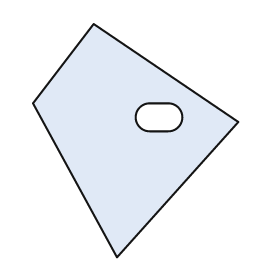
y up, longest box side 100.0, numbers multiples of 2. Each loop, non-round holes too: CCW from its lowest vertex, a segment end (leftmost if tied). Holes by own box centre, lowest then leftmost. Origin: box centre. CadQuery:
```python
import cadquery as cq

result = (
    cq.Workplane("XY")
    .moveTo(-8.0, -50.0)
    .lineTo(44.0, 8.0)
    .lineTo(-18.0, 50.0)
    .lineTo(-44.0, 16.0)
    .close()
    .moveTo(6.0, 4.0)
    .lineTo(14.0, 4.0)
    .threePointArc((20.0, 10.0), (14.0, 16.0))
    .lineTo(6.0, 16.0)
    .threePointArc((0.0, 10.0), (6.0, 4.0))
    .close()
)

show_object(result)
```